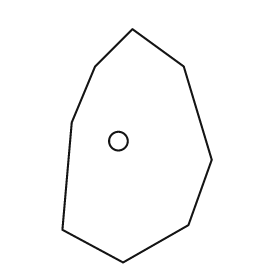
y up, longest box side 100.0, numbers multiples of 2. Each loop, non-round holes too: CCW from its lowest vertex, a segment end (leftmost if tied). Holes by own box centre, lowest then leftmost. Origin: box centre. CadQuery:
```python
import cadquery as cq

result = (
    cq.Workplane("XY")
    .moveTo(-6.0, -50.0)
    .lineTo(22.0, -34.0)
    .lineTo(32.0, -6.0)
    .lineTo(20.0, 34.0)
    .lineTo(-2.0, 50.0)
    .lineTo(-18.0, 34.0)
    .lineTo(-28.0, 10.0)
    .lineTo(-32.0, -36.0)
    .close()
    .moveTo(-8.0, 2.0)
    .circle(4.0)
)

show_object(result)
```